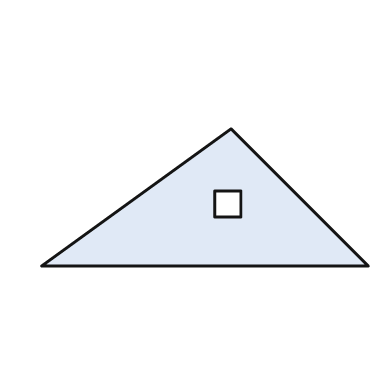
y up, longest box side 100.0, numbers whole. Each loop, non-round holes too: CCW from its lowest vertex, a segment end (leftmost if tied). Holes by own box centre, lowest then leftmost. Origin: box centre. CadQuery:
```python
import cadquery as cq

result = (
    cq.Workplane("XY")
    .moveTo(-50.0, -21.0)
    .lineTo(50.0, -21.0)
    .lineTo(8.0, 21.0)
    .close()
    .moveTo(3.0, -6.0)
    .lineTo(11.0, -6.0)
    .lineTo(11.0, 2.0)
    .lineTo(3.0, 2.0)
    .close()
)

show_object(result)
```